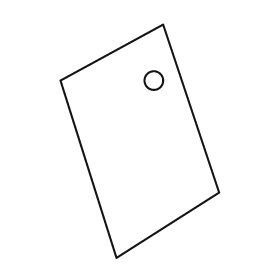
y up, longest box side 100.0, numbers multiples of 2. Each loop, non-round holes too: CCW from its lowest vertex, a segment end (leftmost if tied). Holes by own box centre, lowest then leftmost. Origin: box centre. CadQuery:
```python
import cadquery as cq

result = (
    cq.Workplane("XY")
    .moveTo(-10.0, -50.0)
    .lineTo(34.0, -22.0)
    .lineTo(10.0, 50.0)
    .lineTo(-34.0, 26.0)
    .close()
    .moveTo(6.0, 26.0)
    .circle(4.0)
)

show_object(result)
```